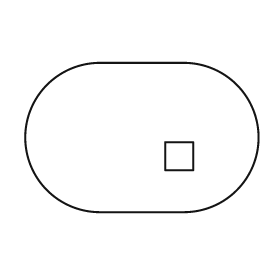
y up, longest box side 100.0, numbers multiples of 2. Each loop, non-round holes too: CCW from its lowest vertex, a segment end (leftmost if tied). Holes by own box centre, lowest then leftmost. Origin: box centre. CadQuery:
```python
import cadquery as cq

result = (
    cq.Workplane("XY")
    .moveTo(-18.0, -32.0)
    .lineTo(18.0, -32.0)
    .threePointArc((50.0, 0.0), (18.0, 32.0))
    .lineTo(-18.0, 32.0)
    .threePointArc((-50.0, 0.0), (-18.0, -32.0))
    .close()
    .moveTo(10.0, -14.0)
    .lineTo(22.0, -14.0)
    .lineTo(22.0, -2.0)
    .lineTo(10.0, -2.0)
    .close()
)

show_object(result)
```